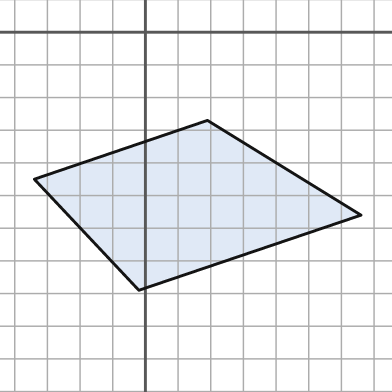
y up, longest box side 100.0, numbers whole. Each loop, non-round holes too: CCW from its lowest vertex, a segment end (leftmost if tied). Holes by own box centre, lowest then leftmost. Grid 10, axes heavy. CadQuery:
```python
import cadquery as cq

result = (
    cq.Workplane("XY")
    .moveTo(-2.0, -79.0)
    .lineTo(66.0, -56.0)
    .lineTo(19.0, -27.0)
    .lineTo(-34.0, -45.0)
    .close()
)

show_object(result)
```